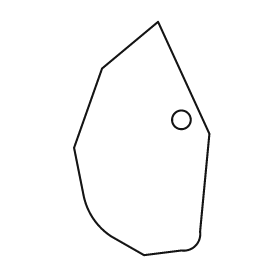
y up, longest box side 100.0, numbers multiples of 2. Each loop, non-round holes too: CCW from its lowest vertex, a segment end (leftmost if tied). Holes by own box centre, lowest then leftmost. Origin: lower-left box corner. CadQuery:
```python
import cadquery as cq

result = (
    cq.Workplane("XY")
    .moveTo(30.0, 0.0)
    .lineTo(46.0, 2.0)
    .threePointArc((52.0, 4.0), (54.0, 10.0))
    .lineTo(58.0, 52.0)
    .lineTo(36.0, 100.0)
    .lineTo(12.0, 80.0)
    .lineTo(0.0, 46.0)
    .lineTo(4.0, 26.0)
    .threePointArc((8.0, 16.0), (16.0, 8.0))
    .close()
    .moveTo(46.0, 58.0)
    .circle(4.0)
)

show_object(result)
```